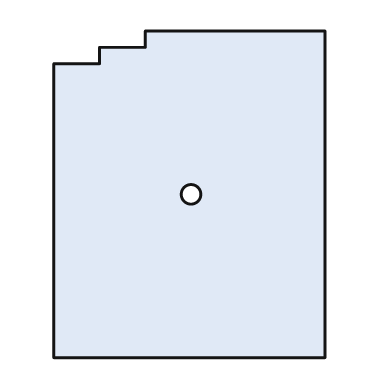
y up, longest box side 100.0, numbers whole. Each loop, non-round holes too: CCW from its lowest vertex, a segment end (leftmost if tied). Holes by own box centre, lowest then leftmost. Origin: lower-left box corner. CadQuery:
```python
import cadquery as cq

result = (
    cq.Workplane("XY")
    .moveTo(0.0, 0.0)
    .lineTo(83.0, 0.0)
    .lineTo(83.0, 100.0)
    .lineTo(28.0, 100.0)
    .lineTo(28.0, 95.0)
    .lineTo(14.0, 95.0)
    .lineTo(14.0, 90.0)
    .lineTo(0.0, 90.0)
    .close()
    .moveTo(42.0, 50.0)
    .circle(3.0)
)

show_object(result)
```